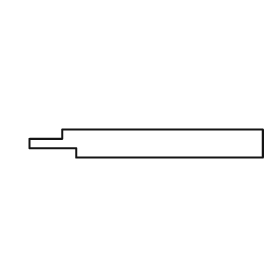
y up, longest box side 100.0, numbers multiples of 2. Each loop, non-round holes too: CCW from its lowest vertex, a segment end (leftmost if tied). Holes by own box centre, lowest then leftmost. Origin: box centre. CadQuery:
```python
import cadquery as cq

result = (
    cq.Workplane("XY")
    .moveTo(-30.0, -6.0)
    .lineTo(50.0, -6.0)
    .lineTo(50.0, 6.0)
    .lineTo(-36.0, 6.0)
    .lineTo(-36.0, 2.0)
    .lineTo(-50.0, 2.0)
    .lineTo(-50.0, -2.0)
    .lineTo(-30.0, -2.0)
    .close()
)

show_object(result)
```